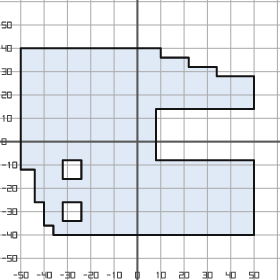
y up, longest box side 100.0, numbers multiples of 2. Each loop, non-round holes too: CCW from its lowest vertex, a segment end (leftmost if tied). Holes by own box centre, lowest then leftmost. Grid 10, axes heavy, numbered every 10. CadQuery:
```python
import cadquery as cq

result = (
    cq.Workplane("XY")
    .moveTo(-36.0, -40.0)
    .lineTo(50.0, -40.0)
    .lineTo(50.0, -8.0)
    .lineTo(8.0, -8.0)
    .lineTo(8.0, 14.0)
    .lineTo(50.0, 14.0)
    .lineTo(50.0, 28.0)
    .lineTo(34.0, 28.0)
    .lineTo(34.0, 32.0)
    .lineTo(22.0, 32.0)
    .lineTo(22.0, 36.0)
    .lineTo(10.0, 36.0)
    .lineTo(10.0, 40.0)
    .lineTo(-50.0, 40.0)
    .lineTo(-50.0, -12.0)
    .lineTo(-44.0, -12.0)
    .lineTo(-44.0, -26.0)
    .lineTo(-40.0, -26.0)
    .lineTo(-40.0, -36.0)
    .lineTo(-36.0, -36.0)
    .close()
    .moveTo(-32.0, -34.0)
    .lineTo(-24.0, -34.0)
    .lineTo(-24.0, -26.0)
    .lineTo(-32.0, -26.0)
    .close()
    .moveTo(-32.0, -16.0)
    .lineTo(-24.0, -16.0)
    .lineTo(-24.0, -8.0)
    .lineTo(-32.0, -8.0)
    .close()
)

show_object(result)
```